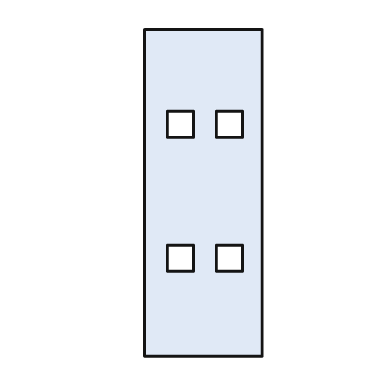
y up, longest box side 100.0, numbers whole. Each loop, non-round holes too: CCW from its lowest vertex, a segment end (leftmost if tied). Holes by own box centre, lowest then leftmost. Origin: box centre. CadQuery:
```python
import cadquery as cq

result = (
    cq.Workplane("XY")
    .moveTo(-18.0, -50.0)
    .lineTo(18.0, -50.0)
    .lineTo(18.0, 50.0)
    .lineTo(-18.0, 50.0)
    .close()
    .moveTo(-11.0, -24.0)
    .lineTo(-3.0, -24.0)
    .lineTo(-3.0, -16.0)
    .lineTo(-11.0, -16.0)
    .close()
    .moveTo(4.0, -24.0)
    .lineTo(12.0, -24.0)
    .lineTo(12.0, -16.0)
    .lineTo(4.0, -16.0)
    .close()
    .moveTo(-11.0, 17.0)
    .lineTo(-3.0, 17.0)
    .lineTo(-3.0, 25.0)
    .lineTo(-11.0, 25.0)
    .close()
    .moveTo(4.0, 17.0)
    .lineTo(12.0, 17.0)
    .lineTo(12.0, 25.0)
    .lineTo(4.0, 25.0)
    .close()
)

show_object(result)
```